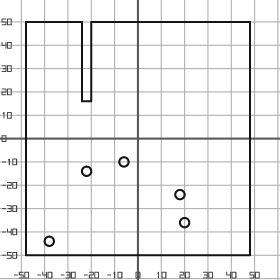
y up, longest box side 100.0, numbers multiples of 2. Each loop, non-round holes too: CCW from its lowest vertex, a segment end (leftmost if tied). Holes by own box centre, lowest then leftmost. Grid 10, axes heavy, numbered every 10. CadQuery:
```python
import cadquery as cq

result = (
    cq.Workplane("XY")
    .moveTo(-48.0, -50.0)
    .lineTo(48.0, -50.0)
    .lineTo(48.0, 50.0)
    .lineTo(-20.0, 50.0)
    .lineTo(-20.0, 16.0)
    .lineTo(-24.0, 16.0)
    .lineTo(-24.0, 50.0)
    .lineTo(-48.0, 50.0)
    .close()
    .moveTo(-38.0, -44.0)
    .circle(2.0)
    .moveTo(20.0, -36.0)
    .circle(2.0)
    .moveTo(18.0, -24.0)
    .circle(2.0)
    .moveTo(-22.0, -14.0)
    .circle(2.0)
    .moveTo(-6.0, -10.0)
    .circle(2.0)
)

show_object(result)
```